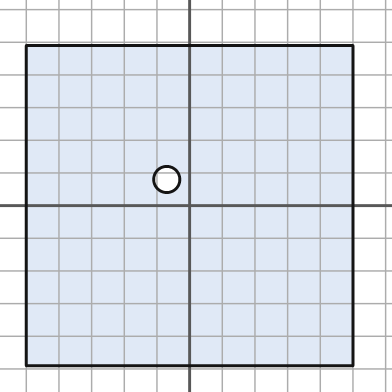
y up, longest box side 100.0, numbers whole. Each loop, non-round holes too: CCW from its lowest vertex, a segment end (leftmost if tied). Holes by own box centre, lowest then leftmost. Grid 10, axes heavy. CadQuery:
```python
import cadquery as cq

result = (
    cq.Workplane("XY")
    .moveTo(-50.0, -49.0)
    .lineTo(50.0, -49.0)
    .lineTo(50.0, 49.0)
    .lineTo(-50.0, 49.0)
    .close()
    .moveTo(-7.0, 8.0)
    .circle(4.0)
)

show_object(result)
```